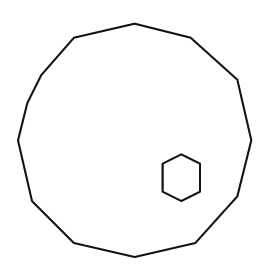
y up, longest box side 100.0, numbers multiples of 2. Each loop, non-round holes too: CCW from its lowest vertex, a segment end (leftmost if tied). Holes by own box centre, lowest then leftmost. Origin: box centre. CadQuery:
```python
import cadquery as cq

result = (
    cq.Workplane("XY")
    .moveTo(0.0, -50.0)
    .lineTo(26.0, -44.0)
    .lineTo(44.0, -24.0)
    .lineTo(50.0, 0.0)
    .lineTo(44.0, 26.0)
    .lineTo(24.0, 44.0)
    .lineTo(0.0, 50.0)
    .lineTo(-26.0, 44.0)
    .lineTo(-40.0, 28.0)
    .lineTo(-46.0, 16.0)
    .lineTo(-50.0, 0.0)
    .lineTo(-44.0, -26.0)
    .lineTo(-26.0, -44.0)
    .close()
    .moveTo(20.0, -26.0)
    .lineTo(28.0, -22.0)
    .lineTo(28.0, -10.0)
    .lineTo(20.0, -6.0)
    .lineTo(12.0, -10.0)
    .lineTo(12.0, -22.0)
    .close()
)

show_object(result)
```